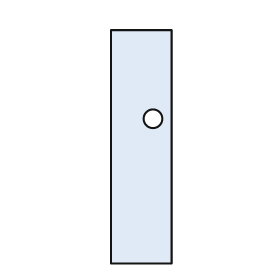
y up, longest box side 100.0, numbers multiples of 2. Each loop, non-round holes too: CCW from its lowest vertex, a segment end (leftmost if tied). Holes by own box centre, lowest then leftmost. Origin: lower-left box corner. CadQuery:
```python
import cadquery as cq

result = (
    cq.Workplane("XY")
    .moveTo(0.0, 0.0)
    .lineTo(26.0, 0.0)
    .lineTo(26.0, 100.0)
    .lineTo(0.0, 100.0)
    .close()
    .moveTo(18.0, 62.0)
    .circle(4.0)
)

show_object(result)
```